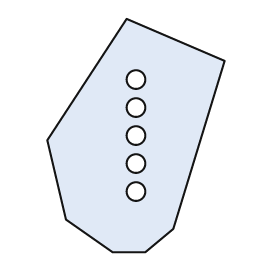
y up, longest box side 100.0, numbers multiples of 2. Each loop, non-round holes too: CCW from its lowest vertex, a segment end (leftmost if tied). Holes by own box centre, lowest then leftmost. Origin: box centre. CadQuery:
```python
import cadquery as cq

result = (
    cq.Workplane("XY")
    .moveTo(-10.0, -50.0)
    .lineTo(4.0, -50.0)
    .lineTo(16.0, -40.0)
    .lineTo(38.0, 32.0)
    .lineTo(-4.0, 50.0)
    .lineTo(-38.0, -2.0)
    .lineTo(-30.0, -36.0)
    .close()
    .moveTo(0.0, -24.0)
    .circle(4.0)
    .moveTo(0.0, -12.0)
    .circle(4.0)
    .moveTo(0.0, 0.0)
    .circle(4.0)
    .moveTo(0.0, 12.0)
    .circle(4.0)
    .moveTo(0.0, 24.0)
    .circle(4.0)
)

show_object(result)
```